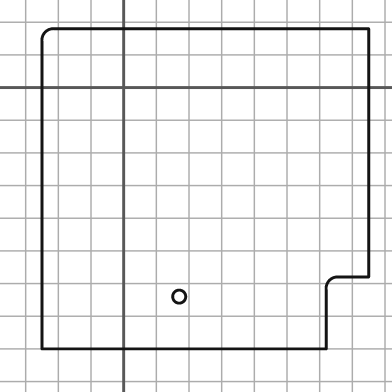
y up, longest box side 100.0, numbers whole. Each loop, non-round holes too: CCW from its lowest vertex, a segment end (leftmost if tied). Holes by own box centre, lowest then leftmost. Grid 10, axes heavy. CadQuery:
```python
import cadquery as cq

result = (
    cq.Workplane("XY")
    .moveTo(-25.0, -80.0)
    .lineTo(62.0, -80.0)
    .lineTo(62.0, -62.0)
    .threePointArc((63.0, -59.0), (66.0, -58.0))
    .lineTo(75.0, -58.0)
    .lineTo(75.0, 18.0)
    .lineTo(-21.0, 18.0)
    .threePointArc((-24.0, 17.0), (-25.0, 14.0))
    .close()
    .moveTo(17.0, -64.0)
    .circle(2.0)
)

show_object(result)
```